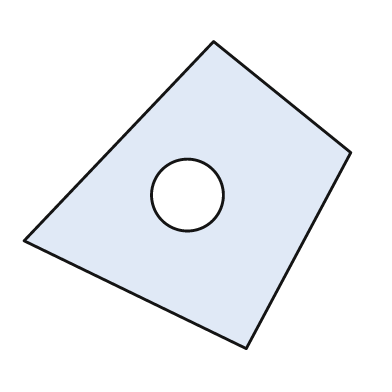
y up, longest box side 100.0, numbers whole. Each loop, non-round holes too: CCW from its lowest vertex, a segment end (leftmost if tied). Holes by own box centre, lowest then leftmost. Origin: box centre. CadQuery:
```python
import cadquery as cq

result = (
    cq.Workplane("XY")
    .moveTo(18.0, -47.0)
    .lineTo(50.0, 13.0)
    .lineTo(8.0, 47.0)
    .lineTo(-50.0, -14.0)
    .close()
    .moveTo(0.0, 0.0)
    .circle(11.0)
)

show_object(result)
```